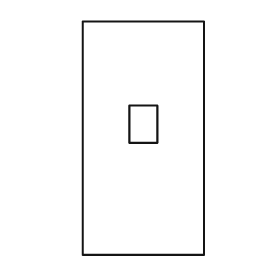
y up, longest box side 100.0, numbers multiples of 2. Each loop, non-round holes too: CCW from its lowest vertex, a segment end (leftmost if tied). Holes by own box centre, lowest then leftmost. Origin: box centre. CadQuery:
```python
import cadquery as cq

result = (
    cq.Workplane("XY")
    .moveTo(-26.0, -50.0)
    .lineTo(26.0, -50.0)
    .lineTo(26.0, 50.0)
    .lineTo(-26.0, 50.0)
    .close()
    .moveTo(-6.0, -2.0)
    .lineTo(6.0, -2.0)
    .lineTo(6.0, 14.0)
    .lineTo(-6.0, 14.0)
    .close()
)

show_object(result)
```